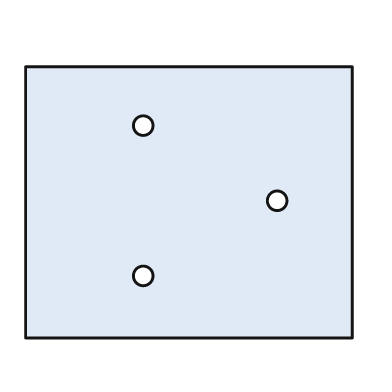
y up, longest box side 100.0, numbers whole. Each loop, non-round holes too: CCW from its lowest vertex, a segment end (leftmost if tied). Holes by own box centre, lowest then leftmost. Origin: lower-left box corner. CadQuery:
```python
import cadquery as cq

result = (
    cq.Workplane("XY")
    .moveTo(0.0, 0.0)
    .lineTo(100.0, 0.0)
    .lineTo(100.0, 83.0)
    .lineTo(0.0, 83.0)
    .close()
    .moveTo(36.0, 19.0)
    .circle(3.0)
    .moveTo(77.0, 42.0)
    .circle(3.0)
    .moveTo(36.0, 65.0)
    .circle(3.0)
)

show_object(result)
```